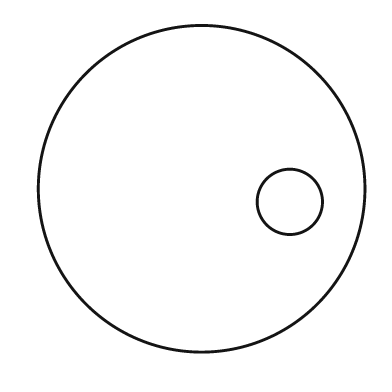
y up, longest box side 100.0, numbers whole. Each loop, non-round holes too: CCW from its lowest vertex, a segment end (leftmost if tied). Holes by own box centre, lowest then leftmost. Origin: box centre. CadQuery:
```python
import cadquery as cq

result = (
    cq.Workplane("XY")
    .moveTo(0.0, 0.0)
    .circle(50.0)
    .moveTo(27.0, -4.0)
    .circle(10.0)
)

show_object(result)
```